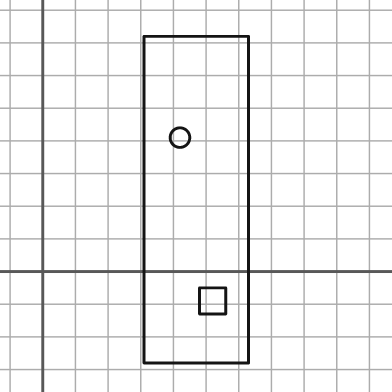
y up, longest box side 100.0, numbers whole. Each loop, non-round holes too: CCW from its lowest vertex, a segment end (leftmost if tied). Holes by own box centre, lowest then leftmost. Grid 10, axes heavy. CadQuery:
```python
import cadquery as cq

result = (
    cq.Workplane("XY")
    .moveTo(31.0, -28.0)
    .lineTo(63.0, -28.0)
    .lineTo(63.0, 72.0)
    .lineTo(31.0, 72.0)
    .close()
    .moveTo(48.0, -13.0)
    .lineTo(56.0, -13.0)
    .lineTo(56.0, -5.0)
    .lineTo(48.0, -5.0)
    .close()
    .moveTo(42.0, 41.0)
    .circle(3.0)
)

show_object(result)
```